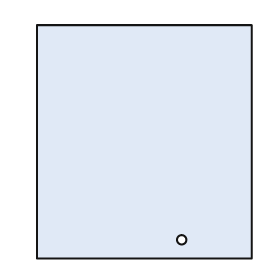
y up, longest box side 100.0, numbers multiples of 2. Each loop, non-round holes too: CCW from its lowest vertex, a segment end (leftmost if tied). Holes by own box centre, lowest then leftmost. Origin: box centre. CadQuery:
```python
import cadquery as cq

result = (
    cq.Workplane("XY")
    .moveTo(-46.0, -50.0)
    .lineTo(46.0, -50.0)
    .lineTo(46.0, 50.0)
    .lineTo(-46.0, 50.0)
    .close()
    .moveTo(16.0, -42.0)
    .circle(2.0)
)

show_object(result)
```